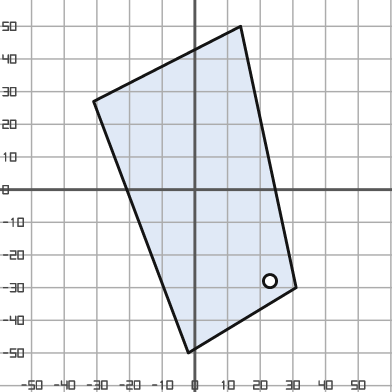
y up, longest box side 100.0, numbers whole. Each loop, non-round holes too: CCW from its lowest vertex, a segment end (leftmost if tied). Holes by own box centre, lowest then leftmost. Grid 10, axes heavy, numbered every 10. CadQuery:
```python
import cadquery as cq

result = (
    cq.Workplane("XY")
    .moveTo(-2.0, -50.0)
    .lineTo(31.0, -30.0)
    .lineTo(14.0, 50.0)
    .lineTo(-31.0, 27.0)
    .close()
    .moveTo(23.0, -28.0)
    .circle(2.0)
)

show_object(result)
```